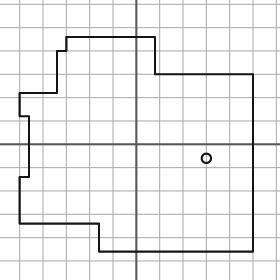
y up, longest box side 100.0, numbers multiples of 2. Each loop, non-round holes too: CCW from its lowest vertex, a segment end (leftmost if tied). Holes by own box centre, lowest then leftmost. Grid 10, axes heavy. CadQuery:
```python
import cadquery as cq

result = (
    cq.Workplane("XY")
    .moveTo(-16.0, -46.0)
    .lineTo(50.0, -46.0)
    .lineTo(50.0, 30.0)
    .lineTo(8.0, 30.0)
    .lineTo(8.0, 46.0)
    .lineTo(-30.0, 46.0)
    .lineTo(-30.0, 40.0)
    .lineTo(-34.0, 40.0)
    .lineTo(-34.0, 22.0)
    .lineTo(-50.0, 22.0)
    .lineTo(-50.0, 12.0)
    .lineTo(-46.0, 12.0)
    .lineTo(-46.0, -14.0)
    .lineTo(-50.0, -14.0)
    .lineTo(-50.0, -34.0)
    .lineTo(-16.0, -34.0)
    .close()
    .moveTo(30.0, -6.0)
    .circle(2.0)
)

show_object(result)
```